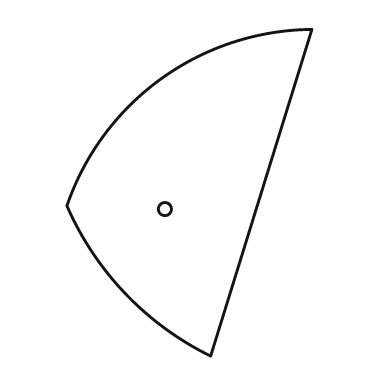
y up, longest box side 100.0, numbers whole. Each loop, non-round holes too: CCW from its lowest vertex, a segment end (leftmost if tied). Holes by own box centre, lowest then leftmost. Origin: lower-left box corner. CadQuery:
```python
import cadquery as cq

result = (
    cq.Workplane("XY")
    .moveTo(44.0, 0.0)
    .lineTo(75.0, 100.0)
    .threePointArc((29.0, 85.0), (0.0, 46.0))
    .threePointArc((18.0, 19.0), (44.0, 0.0))
    .close()
    .moveTo(30.0, 45.0)
    .circle(2.0)
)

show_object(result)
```